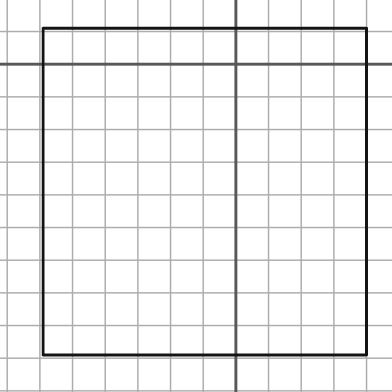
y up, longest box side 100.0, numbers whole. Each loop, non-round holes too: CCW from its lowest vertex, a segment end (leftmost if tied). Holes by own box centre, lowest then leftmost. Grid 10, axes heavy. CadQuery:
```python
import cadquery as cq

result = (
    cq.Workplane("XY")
    .moveTo(-59.0, -89.0)
    .lineTo(40.0, -89.0)
    .lineTo(40.0, 11.0)
    .lineTo(-59.0, 11.0)
    .close()
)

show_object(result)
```